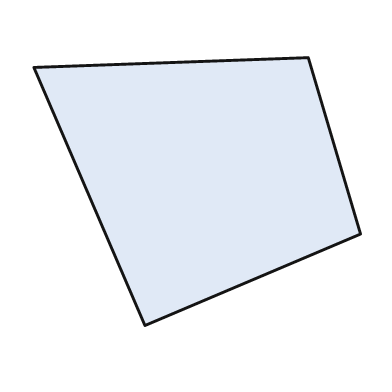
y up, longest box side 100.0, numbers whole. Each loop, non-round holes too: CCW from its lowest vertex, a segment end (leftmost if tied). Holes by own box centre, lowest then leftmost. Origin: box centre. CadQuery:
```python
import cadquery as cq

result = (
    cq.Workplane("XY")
    .moveTo(-16.0, -41.0)
    .lineTo(50.0, -13.0)
    .lineTo(34.0, 41.0)
    .lineTo(-50.0, 38.0)
    .close()
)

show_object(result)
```